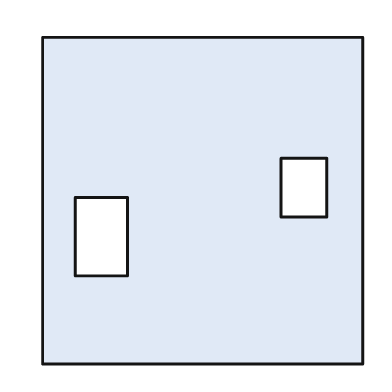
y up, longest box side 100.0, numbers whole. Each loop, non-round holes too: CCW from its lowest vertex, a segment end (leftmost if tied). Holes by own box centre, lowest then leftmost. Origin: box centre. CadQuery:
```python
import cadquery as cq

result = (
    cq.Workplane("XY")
    .moveTo(-49.0, -50.0)
    .lineTo(49.0, -50.0)
    .lineTo(49.0, 50.0)
    .lineTo(-49.0, 50.0)
    .close()
    .moveTo(-39.0, -23.0)
    .lineTo(-23.0, -23.0)
    .lineTo(-23.0, 1.0)
    .lineTo(-39.0, 1.0)
    .close()
    .moveTo(24.0, -5.0)
    .lineTo(38.0, -5.0)
    .lineTo(38.0, 13.0)
    .lineTo(24.0, 13.0)
    .close()
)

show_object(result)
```